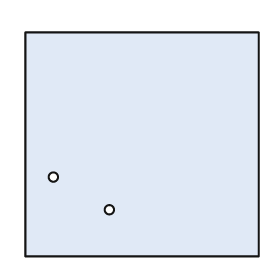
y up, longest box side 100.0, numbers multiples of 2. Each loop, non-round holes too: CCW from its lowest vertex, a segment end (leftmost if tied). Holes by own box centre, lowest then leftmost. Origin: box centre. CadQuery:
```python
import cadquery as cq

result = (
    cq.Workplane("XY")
    .moveTo(-50.0, -48.0)
    .lineTo(50.0, -48.0)
    .lineTo(50.0, 48.0)
    .lineTo(-50.0, 48.0)
    .close()
    .moveTo(-14.0, -28.0)
    .circle(2.0)
    .moveTo(-38.0, -14.0)
    .circle(2.0)
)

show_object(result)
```